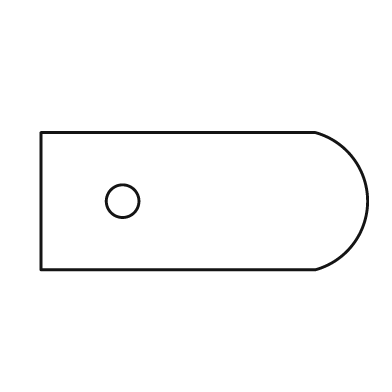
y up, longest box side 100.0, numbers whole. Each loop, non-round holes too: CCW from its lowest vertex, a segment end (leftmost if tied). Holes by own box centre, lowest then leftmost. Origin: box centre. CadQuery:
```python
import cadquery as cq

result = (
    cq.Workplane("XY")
    .moveTo(-50.0, -21.0)
    .lineTo(34.0, -21.0)
    .threePointArc((50.0, 0.0), (34.0, 21.0))
    .lineTo(-50.0, 21.0)
    .close()
    .moveTo(-25.0, 0.0)
    .circle(5.0)
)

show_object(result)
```